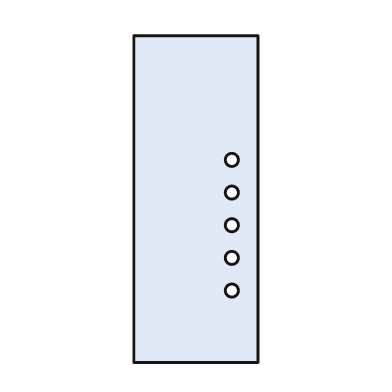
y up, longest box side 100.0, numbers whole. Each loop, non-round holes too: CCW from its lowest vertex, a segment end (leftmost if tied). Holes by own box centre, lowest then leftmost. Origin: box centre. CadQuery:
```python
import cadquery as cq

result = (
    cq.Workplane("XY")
    .moveTo(-19.0, -50.0)
    .lineTo(19.0, -50.0)
    .lineTo(19.0, 50.0)
    .lineTo(-19.0, 50.0)
    .close()
    .moveTo(11.0, -28.0)
    .circle(2.0)
    .moveTo(11.0, -18.0)
    .circle(2.0)
    .moveTo(11.0, -8.0)
    .circle(2.0)
    .moveTo(11.0, 2.0)
    .circle(2.0)
    .moveTo(11.0, 12.0)
    .circle(2.0)
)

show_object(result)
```